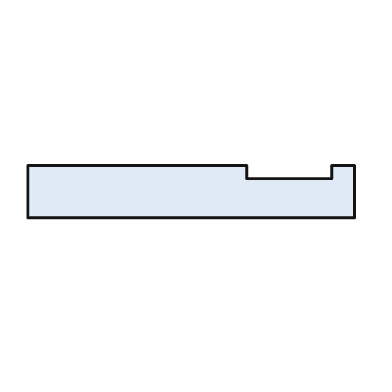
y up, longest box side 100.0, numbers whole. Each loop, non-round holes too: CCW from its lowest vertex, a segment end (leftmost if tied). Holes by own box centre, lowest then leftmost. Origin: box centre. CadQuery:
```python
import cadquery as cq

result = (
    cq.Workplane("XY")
    .moveTo(-50.0, -8.0)
    .lineTo(50.0, -8.0)
    .lineTo(50.0, 8.0)
    .lineTo(43.0, 8.0)
    .lineTo(43.0, 4.0)
    .lineTo(17.0, 4.0)
    .lineTo(17.0, 8.0)
    .lineTo(-50.0, 8.0)
    .close()
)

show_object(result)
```